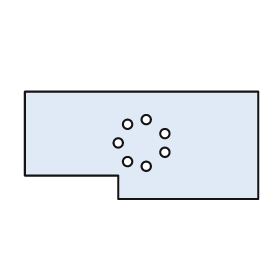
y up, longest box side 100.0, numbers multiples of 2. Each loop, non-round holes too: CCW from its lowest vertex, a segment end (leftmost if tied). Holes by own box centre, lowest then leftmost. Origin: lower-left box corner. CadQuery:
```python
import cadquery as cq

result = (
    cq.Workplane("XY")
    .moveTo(40.0, 0.0)
    .lineTo(100.0, 0.0)
    .lineTo(100.0, 46.0)
    .lineTo(0.0, 46.0)
    .lineTo(0.0, 10.0)
    .lineTo(40.0, 10.0)
    .close()
    .moveTo(52.0, 14.0)
    .circle(2.0)
    .moveTo(44.0, 16.0)
    .circle(2.0)
    .moveTo(60.0, 20.0)
    .circle(2.0)
    .moveTo(40.0, 24.0)
    .circle(2.0)
    .moveTo(60.0, 28.0)
    .circle(2.0)
    .moveTo(44.0, 32.0)
    .circle(2.0)
    .moveTo(52.0, 34.0)
    .circle(2.0)
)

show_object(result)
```